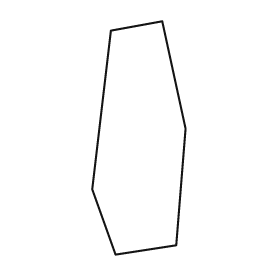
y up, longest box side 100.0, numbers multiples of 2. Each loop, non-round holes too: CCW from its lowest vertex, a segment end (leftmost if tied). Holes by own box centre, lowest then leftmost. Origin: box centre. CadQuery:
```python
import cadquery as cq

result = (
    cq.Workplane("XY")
    .moveTo(-10.0, -50.0)
    .lineTo(16.0, -46.0)
    .lineTo(20.0, 4.0)
    .lineTo(10.0, 50.0)
    .lineTo(-12.0, 46.0)
    .lineTo(-20.0, -22.0)
    .close()
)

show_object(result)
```